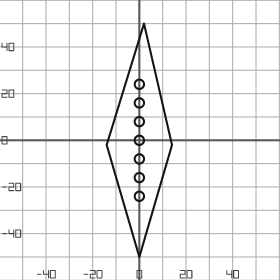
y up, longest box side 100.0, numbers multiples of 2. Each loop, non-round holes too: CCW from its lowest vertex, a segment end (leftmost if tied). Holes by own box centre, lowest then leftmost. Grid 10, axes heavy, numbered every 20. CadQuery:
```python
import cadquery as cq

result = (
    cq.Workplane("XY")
    .moveTo(0.0, -50.0)
    .lineTo(14.0, -2.0)
    .lineTo(2.0, 50.0)
    .lineTo(-14.0, -2.0)
    .close()
    .moveTo(0.0, -24.0)
    .circle(2.0)
    .moveTo(0.0, -16.0)
    .circle(2.0)
    .moveTo(0.0, -8.0)
    .circle(2.0)
    .moveTo(0.0, 0.0)
    .circle(2.0)
    .moveTo(0.0, 8.0)
    .circle(2.0)
    .moveTo(0.0, 16.0)
    .circle(2.0)
    .moveTo(0.0, 24.0)
    .circle(2.0)
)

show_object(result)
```